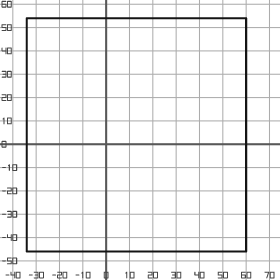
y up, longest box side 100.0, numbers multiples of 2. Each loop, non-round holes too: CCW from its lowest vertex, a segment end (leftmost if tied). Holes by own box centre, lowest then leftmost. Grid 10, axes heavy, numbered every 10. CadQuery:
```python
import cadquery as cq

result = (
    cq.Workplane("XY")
    .moveTo(-34.0, -46.0)
    .lineTo(60.0, -46.0)
    .lineTo(60.0, 54.0)
    .lineTo(-34.0, 54.0)
    .close()
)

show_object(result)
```